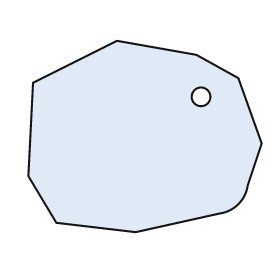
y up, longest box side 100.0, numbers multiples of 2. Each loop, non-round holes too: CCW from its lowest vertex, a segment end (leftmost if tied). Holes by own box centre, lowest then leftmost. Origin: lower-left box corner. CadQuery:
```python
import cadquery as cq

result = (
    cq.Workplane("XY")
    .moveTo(46.0, 0.0)
    .lineTo(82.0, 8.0)
    .threePointArc((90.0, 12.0), (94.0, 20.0))
    .lineTo(100.0, 38.0)
    .lineTo(90.0, 66.0)
    .lineTo(72.0, 76.0)
    .lineTo(38.0, 82.0)
    .lineTo(2.0, 64.0)
    .lineTo(0.0, 24.0)
    .lineTo(12.0, 4.0)
    .close()
    .moveTo(74.0, 58.0)
    .circle(4.0)
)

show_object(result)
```